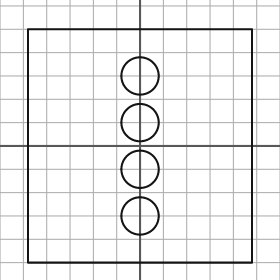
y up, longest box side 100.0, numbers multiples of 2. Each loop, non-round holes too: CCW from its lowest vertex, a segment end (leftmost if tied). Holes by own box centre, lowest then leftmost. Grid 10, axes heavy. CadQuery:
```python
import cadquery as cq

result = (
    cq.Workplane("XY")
    .moveTo(-48.0, -50.0)
    .lineTo(48.0, -50.0)
    .lineTo(48.0, 50.0)
    .lineTo(-48.0, 50.0)
    .close()
    .moveTo(0.0, -30.0)
    .circle(8.0)
    .moveTo(0.0, -10.0)
    .circle(8.0)
    .moveTo(0.0, 10.0)
    .circle(8.0)
    .moveTo(0.0, 30.0)
    .circle(8.0)
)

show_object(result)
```